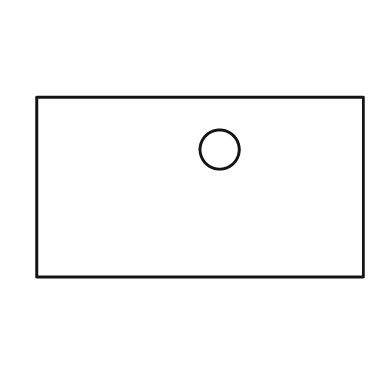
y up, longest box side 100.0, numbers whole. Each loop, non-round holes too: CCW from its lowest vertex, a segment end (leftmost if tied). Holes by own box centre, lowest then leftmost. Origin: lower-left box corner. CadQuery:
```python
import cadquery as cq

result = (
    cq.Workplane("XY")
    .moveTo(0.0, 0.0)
    .lineTo(100.0, 0.0)
    .lineTo(100.0, 55.0)
    .lineTo(0.0, 55.0)
    .close()
    .moveTo(56.0, 39.0)
    .circle(6.0)
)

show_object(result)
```